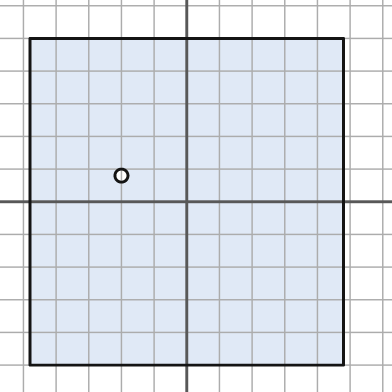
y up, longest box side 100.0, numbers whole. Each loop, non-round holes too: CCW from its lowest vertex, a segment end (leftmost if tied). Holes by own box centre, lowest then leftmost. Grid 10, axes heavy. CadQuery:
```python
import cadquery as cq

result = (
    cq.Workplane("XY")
    .moveTo(-48.0, -50.0)
    .lineTo(48.0, -50.0)
    .lineTo(48.0, 50.0)
    .lineTo(-48.0, 50.0)
    .close()
    .moveTo(-20.0, 8.0)
    .circle(2.0)
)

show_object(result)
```